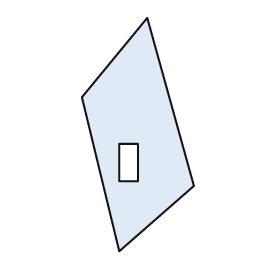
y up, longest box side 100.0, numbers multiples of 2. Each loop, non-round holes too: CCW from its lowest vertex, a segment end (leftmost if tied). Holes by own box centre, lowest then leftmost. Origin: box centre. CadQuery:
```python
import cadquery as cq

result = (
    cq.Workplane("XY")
    .moveTo(-8.0, -50.0)
    .lineTo(24.0, -22.0)
    .lineTo(4.0, 50.0)
    .lineTo(-24.0, 16.0)
    .close()
    .moveTo(-8.0, -20.0)
    .lineTo(0.0, -20.0)
    .lineTo(0.0, -4.0)
    .lineTo(-8.0, -4.0)
    .close()
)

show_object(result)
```